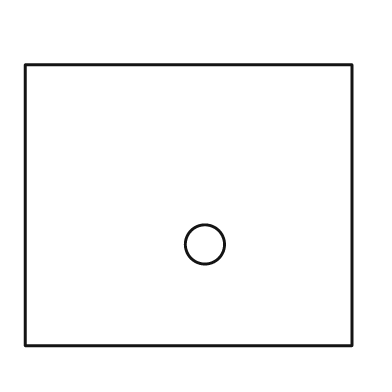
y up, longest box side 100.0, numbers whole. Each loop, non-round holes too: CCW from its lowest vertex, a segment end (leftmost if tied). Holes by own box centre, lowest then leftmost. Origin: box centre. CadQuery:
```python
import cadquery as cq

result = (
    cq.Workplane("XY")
    .moveTo(-50.0, -43.0)
    .lineTo(50.0, -43.0)
    .lineTo(50.0, 43.0)
    .lineTo(-50.0, 43.0)
    .close()
    .moveTo(5.0, -12.0)
    .circle(6.0)
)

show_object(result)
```